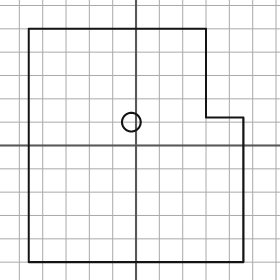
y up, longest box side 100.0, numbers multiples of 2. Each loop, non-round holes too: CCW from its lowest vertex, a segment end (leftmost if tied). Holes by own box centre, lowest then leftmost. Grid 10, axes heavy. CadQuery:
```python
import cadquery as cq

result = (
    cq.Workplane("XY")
    .moveTo(-46.0, -50.0)
    .lineTo(46.0, -50.0)
    .lineTo(46.0, 12.0)
    .lineTo(30.0, 12.0)
    .lineTo(30.0, 50.0)
    .lineTo(-46.0, 50.0)
    .close()
    .moveTo(-2.0, 10.0)
    .circle(4.0)
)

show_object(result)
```